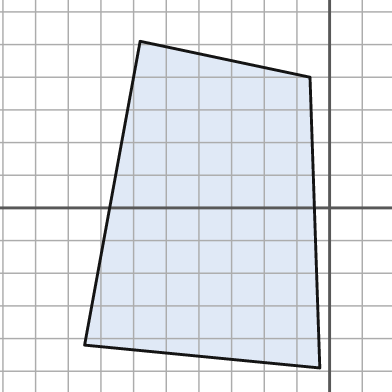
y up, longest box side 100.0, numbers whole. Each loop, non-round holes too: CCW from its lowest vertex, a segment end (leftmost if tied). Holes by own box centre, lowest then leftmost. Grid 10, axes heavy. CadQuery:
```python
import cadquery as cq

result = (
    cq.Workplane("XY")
    .moveTo(-3.0, -49.0)
    .lineTo(-6.0, 40.0)
    .lineTo(-58.0, 51.0)
    .lineTo(-75.0, -42.0)
    .close()
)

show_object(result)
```